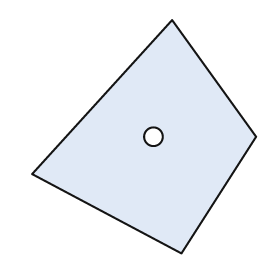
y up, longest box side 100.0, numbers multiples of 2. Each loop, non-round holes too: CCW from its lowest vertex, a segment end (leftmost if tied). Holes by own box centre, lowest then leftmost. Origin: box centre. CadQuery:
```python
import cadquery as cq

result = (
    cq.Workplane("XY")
    .moveTo(16.0, -50.0)
    .lineTo(48.0, 0.0)
    .lineTo(12.0, 50.0)
    .lineTo(-48.0, -16.0)
    .close()
    .moveTo(4.0, 0.0)
    .circle(4.0)
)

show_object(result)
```